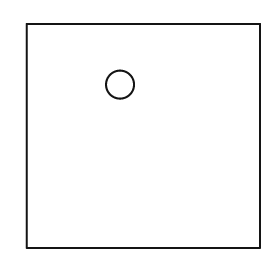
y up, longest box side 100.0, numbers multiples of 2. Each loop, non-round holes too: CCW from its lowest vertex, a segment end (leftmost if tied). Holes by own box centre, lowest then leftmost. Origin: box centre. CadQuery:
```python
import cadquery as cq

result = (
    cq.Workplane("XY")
    .moveTo(-50.0, -48.0)
    .lineTo(50.0, -48.0)
    .lineTo(50.0, 48.0)
    .lineTo(-50.0, 48.0)
    .close()
    .moveTo(-10.0, 22.0)
    .circle(6.0)
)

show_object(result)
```